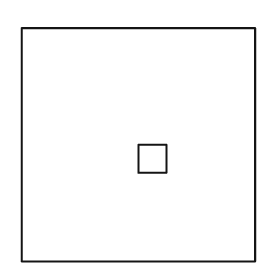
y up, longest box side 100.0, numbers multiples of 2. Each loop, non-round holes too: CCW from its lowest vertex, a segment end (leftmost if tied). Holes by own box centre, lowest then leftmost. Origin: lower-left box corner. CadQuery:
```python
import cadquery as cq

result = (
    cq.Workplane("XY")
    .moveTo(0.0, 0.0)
    .lineTo(100.0, 0.0)
    .lineTo(100.0, 100.0)
    .lineTo(0.0, 100.0)
    .close()
    .moveTo(50.0, 38.0)
    .lineTo(62.0, 38.0)
    .lineTo(62.0, 50.0)
    .lineTo(50.0, 50.0)
    .close()
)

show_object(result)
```